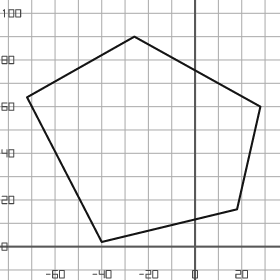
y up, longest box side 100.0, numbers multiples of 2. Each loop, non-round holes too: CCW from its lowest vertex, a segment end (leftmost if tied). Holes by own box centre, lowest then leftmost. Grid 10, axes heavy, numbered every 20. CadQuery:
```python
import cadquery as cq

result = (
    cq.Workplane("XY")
    .moveTo(-40.0, 2.0)
    .lineTo(18.0, 16.0)
    .lineTo(28.0, 60.0)
    .lineTo(-26.0, 90.0)
    .lineTo(-72.0, 64.0)
    .close()
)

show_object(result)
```